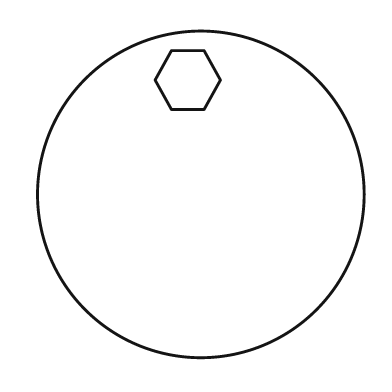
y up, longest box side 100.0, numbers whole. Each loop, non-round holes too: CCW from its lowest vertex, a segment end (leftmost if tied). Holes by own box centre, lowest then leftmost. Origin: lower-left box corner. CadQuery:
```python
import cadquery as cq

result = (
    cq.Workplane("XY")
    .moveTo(50.0, 50.0)
    .circle(50.0)
    .moveTo(41.0, 76.0)
    .lineTo(51.0, 76.0)
    .lineTo(56.0, 85.0)
    .lineTo(51.0, 94.0)
    .lineTo(41.0, 94.0)
    .lineTo(36.0, 85.0)
    .close()
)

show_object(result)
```